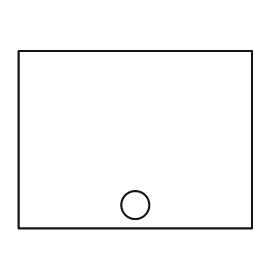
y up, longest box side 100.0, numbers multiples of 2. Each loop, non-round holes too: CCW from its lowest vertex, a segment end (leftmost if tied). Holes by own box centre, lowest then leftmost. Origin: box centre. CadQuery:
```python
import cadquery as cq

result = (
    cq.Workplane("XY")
    .moveTo(-50.0, -38.0)
    .lineTo(50.0, -38.0)
    .lineTo(50.0, 38.0)
    .lineTo(-50.0, 38.0)
    .close()
    .moveTo(0.0, -28.0)
    .circle(6.0)
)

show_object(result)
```